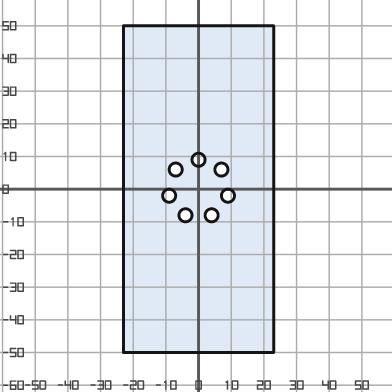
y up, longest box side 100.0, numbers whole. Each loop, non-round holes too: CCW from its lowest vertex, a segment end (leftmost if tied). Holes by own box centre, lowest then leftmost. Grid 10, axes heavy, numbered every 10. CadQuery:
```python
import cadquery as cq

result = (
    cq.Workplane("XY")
    .moveTo(-23.0, -50.0)
    .lineTo(23.0, -50.0)
    .lineTo(23.0, 50.0)
    .lineTo(-23.0, 50.0)
    .close()
    .moveTo(-4.0, -8.0)
    .circle(2.0)
    .moveTo(4.0, -8.0)
    .circle(2.0)
    .moveTo(-9.0, -2.0)
    .circle(2.0)
    .moveTo(9.0, -2.0)
    .circle(2.0)
    .moveTo(-7.0, 6.0)
    .circle(2.0)
    .moveTo(7.0, 6.0)
    .circle(2.0)
    .moveTo(0.0, 9.0)
    .circle(2.0)
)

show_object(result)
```